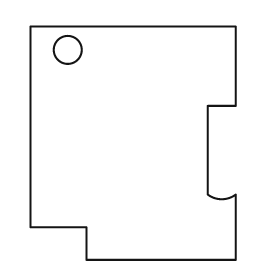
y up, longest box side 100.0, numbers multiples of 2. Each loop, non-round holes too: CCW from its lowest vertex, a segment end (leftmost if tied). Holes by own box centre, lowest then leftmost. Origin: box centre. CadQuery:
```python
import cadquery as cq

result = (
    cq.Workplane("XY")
    .moveTo(-20.0, -50.0)
    .lineTo(44.0, -50.0)
    .lineTo(44.0, -22.0)
    .threePointArc((38.0, -24.0), (32.0, -22.0))
    .lineTo(32.0, 16.0)
    .lineTo(44.0, 16.0)
    .lineTo(44.0, 50.0)
    .lineTo(-44.0, 50.0)
    .lineTo(-44.0, -36.0)
    .lineTo(-20.0, -36.0)
    .close()
    .moveTo(-28.0, 40.0)
    .circle(6.0)
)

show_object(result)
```